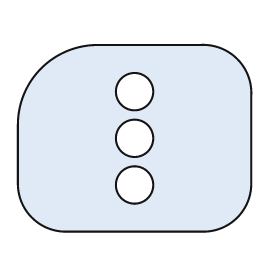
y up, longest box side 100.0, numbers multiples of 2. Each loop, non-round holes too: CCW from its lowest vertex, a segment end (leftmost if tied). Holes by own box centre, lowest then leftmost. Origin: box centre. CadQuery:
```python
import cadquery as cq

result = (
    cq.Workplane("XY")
    .moveTo(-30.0, -40.0)
    .lineTo(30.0, -40.0)
    .threePointArc((44.0, -34.0), (50.0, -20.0))
    .lineTo(50.0, 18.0)
    .threePointArc((44.0, 34.0), (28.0, 40.0))
    .lineTo(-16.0, 40.0)
    .threePointArc((-40.0, 30.0), (-50.0, 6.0))
    .lineTo(-50.0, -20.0)
    .threePointArc((-44.0, -34.0), (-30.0, -40.0))
    .close()
    .moveTo(0.0, -20.0)
    .circle(8.0)
    .moveTo(0.0, 0.0)
    .circle(8.0)
    .moveTo(0.0, 20.0)
    .circle(8.0)
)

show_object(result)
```